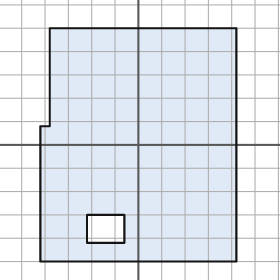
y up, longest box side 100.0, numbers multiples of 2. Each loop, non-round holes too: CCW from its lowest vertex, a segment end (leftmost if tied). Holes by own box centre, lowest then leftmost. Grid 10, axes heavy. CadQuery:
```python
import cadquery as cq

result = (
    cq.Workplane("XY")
    .moveTo(-42.0, -50.0)
    .lineTo(42.0, -50.0)
    .lineTo(42.0, 50.0)
    .lineTo(-38.0, 50.0)
    .lineTo(-38.0, 8.0)
    .lineTo(-42.0, 8.0)
    .close()
    .moveTo(-22.0, -42.0)
    .lineTo(-6.0, -42.0)
    .lineTo(-6.0, -30.0)
    .lineTo(-22.0, -30.0)
    .close()
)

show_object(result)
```